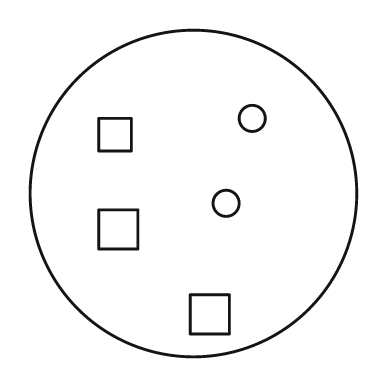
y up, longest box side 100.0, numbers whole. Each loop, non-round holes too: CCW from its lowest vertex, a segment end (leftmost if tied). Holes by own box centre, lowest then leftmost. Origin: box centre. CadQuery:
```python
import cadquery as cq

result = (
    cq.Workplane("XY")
    .moveTo(0.0, 0.0)
    .circle(50.0)
    .moveTo(-1.0, -43.0)
    .lineTo(11.0, -43.0)
    .lineTo(11.0, -31.0)
    .lineTo(-1.0, -31.0)
    .close()
    .moveTo(-29.0, -17.0)
    .lineTo(-17.0, -17.0)
    .lineTo(-17.0, -5.0)
    .lineTo(-29.0, -5.0)
    .close()
    .moveTo(10.0, -3.0)
    .circle(4.0)
    .moveTo(-29.0, 13.0)
    .lineTo(-19.0, 13.0)
    .lineTo(-19.0, 23.0)
    .lineTo(-29.0, 23.0)
    .close()
    .moveTo(18.0, 23.0)
    .circle(4.0)
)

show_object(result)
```